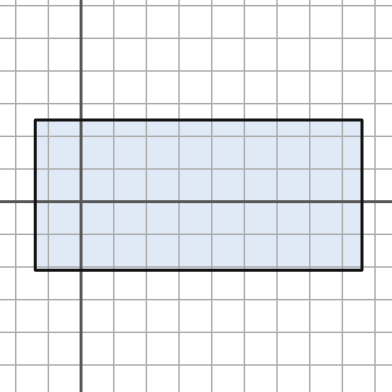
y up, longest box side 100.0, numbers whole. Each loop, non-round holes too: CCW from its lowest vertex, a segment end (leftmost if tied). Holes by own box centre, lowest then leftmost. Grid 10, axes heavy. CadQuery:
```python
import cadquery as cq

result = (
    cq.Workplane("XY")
    .moveTo(-14.0, -21.0)
    .lineTo(86.0, -21.0)
    .lineTo(86.0, 25.0)
    .lineTo(-14.0, 25.0)
    .close()
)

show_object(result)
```